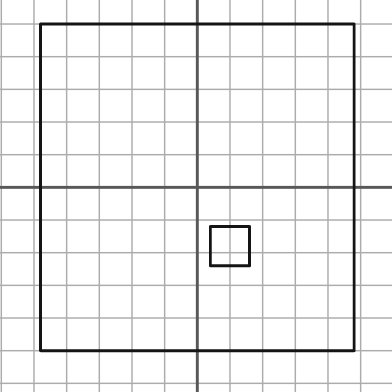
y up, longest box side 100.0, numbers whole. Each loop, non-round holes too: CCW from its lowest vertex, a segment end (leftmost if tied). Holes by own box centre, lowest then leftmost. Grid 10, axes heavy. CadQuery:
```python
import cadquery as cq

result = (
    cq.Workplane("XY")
    .moveTo(-48.0, -50.0)
    .lineTo(48.0, -50.0)
    .lineTo(48.0, 50.0)
    .lineTo(-48.0, 50.0)
    .close()
    .moveTo(4.0, -24.0)
    .lineTo(16.0, -24.0)
    .lineTo(16.0, -12.0)
    .lineTo(4.0, -12.0)
    .close()
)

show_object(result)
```